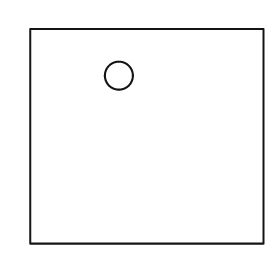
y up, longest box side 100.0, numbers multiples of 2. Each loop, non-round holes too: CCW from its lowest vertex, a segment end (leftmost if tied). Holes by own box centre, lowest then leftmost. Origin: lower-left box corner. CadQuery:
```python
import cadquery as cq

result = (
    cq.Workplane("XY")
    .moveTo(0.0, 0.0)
    .lineTo(100.0, 0.0)
    .lineTo(100.0, 92.0)
    .lineTo(0.0, 92.0)
    .close()
    .moveTo(38.0, 72.0)
    .circle(6.0)
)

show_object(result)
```